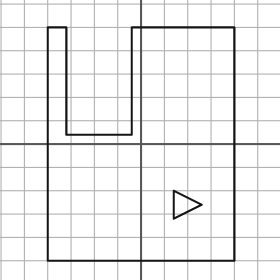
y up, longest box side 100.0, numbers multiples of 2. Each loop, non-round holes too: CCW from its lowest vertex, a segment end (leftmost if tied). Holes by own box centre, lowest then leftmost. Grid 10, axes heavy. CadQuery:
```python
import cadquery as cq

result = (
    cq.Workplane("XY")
    .moveTo(-40.0, -50.0)
    .lineTo(40.0, -50.0)
    .lineTo(40.0, 50.0)
    .lineTo(-4.0, 50.0)
    .lineTo(-4.0, 4.0)
    .lineTo(-32.0, 4.0)
    .lineTo(-32.0, 50.0)
    .lineTo(-40.0, 50.0)
    .close()
    .moveTo(14.0, -32.0)
    .lineTo(26.0, -26.0)
    .lineTo(14.0, -20.0)
    .close()
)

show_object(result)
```